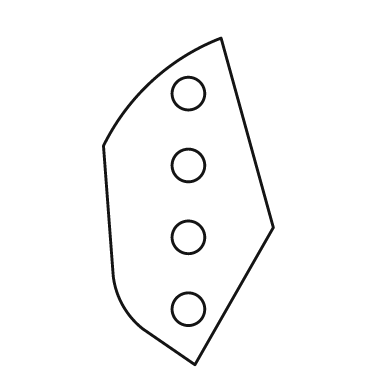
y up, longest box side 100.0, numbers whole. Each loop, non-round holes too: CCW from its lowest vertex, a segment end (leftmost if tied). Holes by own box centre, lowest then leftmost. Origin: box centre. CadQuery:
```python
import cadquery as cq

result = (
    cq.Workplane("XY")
    .moveTo(2.0, -50.0)
    .lineTo(26.0, -8.0)
    .lineTo(10.0, 50.0)
    .threePointArc((-11.0, 37.0), (-26.0, 17.0))
    .lineTo(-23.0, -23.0)
    .threePointArc((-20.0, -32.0), (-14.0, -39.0))
    .close()
    .moveTo(0.0, -33.0)
    .circle(5.0)
    .moveTo(0.0, -11.0)
    .circle(5.0)
    .moveTo(0.0, 11.0)
    .circle(5.0)
    .moveTo(0.0, 33.0)
    .circle(5.0)
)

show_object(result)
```